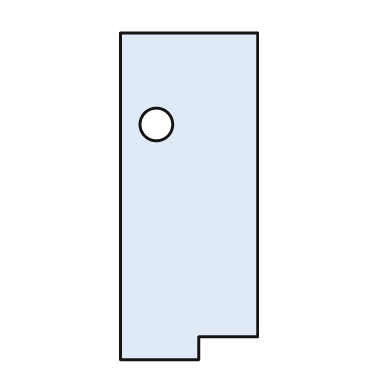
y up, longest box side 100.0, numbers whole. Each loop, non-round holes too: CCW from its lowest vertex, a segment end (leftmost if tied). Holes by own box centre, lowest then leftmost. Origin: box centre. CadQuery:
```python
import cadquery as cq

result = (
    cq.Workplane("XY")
    .moveTo(-21.0, -50.0)
    .lineTo(3.0, -50.0)
    .lineTo(3.0, -43.0)
    .lineTo(21.0, -43.0)
    .lineTo(21.0, 50.0)
    .lineTo(-21.0, 50.0)
    .close()
    .moveTo(-10.0, 22.0)
    .circle(5.0)
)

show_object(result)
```